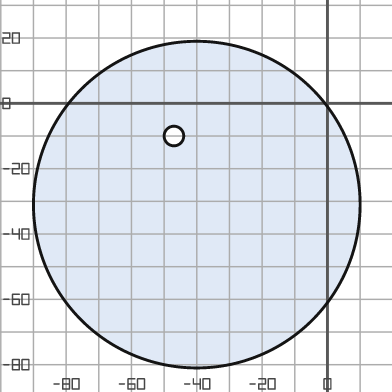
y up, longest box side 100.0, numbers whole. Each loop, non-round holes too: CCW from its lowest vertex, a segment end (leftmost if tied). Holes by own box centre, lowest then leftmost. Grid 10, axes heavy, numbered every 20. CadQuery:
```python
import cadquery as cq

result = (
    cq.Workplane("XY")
    .moveTo(-40.0, -31.0)
    .circle(50.0)
    .moveTo(-47.0, -10.0)
    .circle(3.0)
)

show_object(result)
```